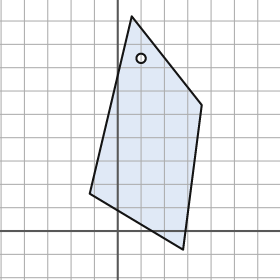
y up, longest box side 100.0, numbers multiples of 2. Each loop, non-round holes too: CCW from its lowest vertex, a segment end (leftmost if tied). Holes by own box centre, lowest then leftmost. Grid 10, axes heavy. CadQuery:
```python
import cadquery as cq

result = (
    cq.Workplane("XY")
    .moveTo(28.0, -8.0)
    .lineTo(36.0, 54.0)
    .lineTo(6.0, 92.0)
    .lineTo(-12.0, 16.0)
    .close()
    .moveTo(10.0, 74.0)
    .circle(2.0)
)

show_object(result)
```